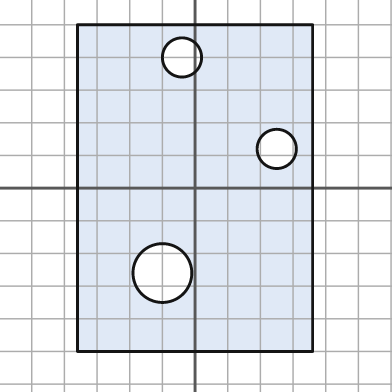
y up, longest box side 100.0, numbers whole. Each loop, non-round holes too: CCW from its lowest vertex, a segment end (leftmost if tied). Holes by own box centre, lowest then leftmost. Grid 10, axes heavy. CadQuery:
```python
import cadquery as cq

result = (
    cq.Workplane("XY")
    .moveTo(-36.0, -50.0)
    .lineTo(36.0, -50.0)
    .lineTo(36.0, 50.0)
    .lineTo(-36.0, 50.0)
    .close()
    .moveTo(-10.0, -26.0)
    .circle(9.0)
    .moveTo(25.0, 12.0)
    .circle(6.0)
    .moveTo(-4.0, 40.0)
    .circle(6.0)
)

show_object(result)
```